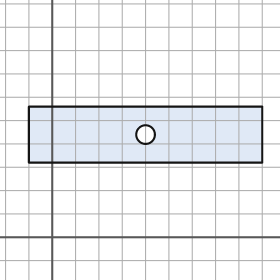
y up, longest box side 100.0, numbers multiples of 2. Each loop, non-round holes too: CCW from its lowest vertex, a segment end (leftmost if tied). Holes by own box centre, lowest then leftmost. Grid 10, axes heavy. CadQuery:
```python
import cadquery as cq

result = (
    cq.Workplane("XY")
    .moveTo(-10.0, 32.0)
    .lineTo(90.0, 32.0)
    .lineTo(90.0, 56.0)
    .lineTo(-10.0, 56.0)
    .close()
    .moveTo(40.0, 44.0)
    .circle(4.0)
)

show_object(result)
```